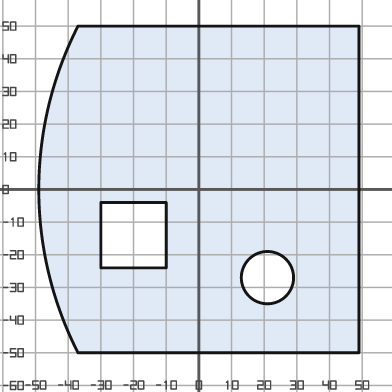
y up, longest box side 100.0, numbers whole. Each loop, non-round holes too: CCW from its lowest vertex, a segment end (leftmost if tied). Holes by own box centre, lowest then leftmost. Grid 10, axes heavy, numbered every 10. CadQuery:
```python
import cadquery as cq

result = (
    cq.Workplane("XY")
    .moveTo(-37.0, -50.0)
    .lineTo(49.0, -50.0)
    .lineTo(49.0, 50.0)
    .lineTo(-37.0, 50.0)
    .threePointArc((-49.0, 0.0), (-37.0, -50.0))
    .close()
    .moveTo(21.0, -27.0)
    .circle(8.0)
    .moveTo(-30.0, -24.0)
    .lineTo(-10.0, -24.0)
    .lineTo(-10.0, -4.0)
    .lineTo(-30.0, -4.0)
    .close()
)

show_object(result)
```